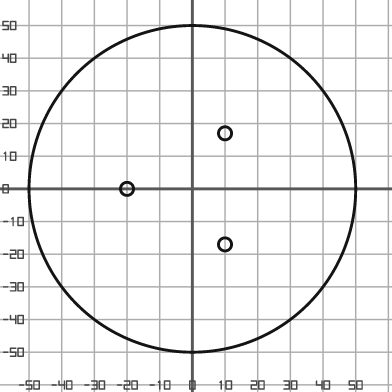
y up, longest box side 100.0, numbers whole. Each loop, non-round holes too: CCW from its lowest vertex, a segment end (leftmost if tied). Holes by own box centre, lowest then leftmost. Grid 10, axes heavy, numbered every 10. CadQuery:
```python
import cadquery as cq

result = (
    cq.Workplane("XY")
    .moveTo(0.0, 0.0)
    .circle(50.0)
    .moveTo(10.0, -17.0)
    .circle(2.0)
    .moveTo(-20.0, 0.0)
    .circle(2.0)
    .moveTo(10.0, 17.0)
    .circle(2.0)
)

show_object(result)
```